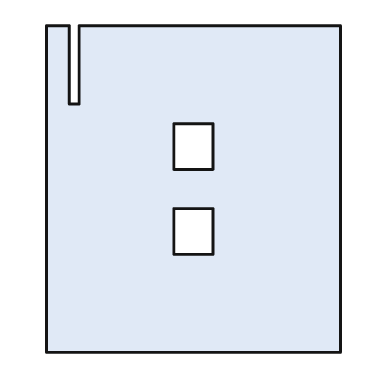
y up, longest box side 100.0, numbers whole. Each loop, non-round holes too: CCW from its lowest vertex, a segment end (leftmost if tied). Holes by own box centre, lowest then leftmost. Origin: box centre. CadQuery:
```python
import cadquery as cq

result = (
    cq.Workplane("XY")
    .moveTo(-45.0, -50.0)
    .lineTo(45.0, -50.0)
    .lineTo(45.0, 50.0)
    .lineTo(-35.0, 50.0)
    .lineTo(-35.0, 26.0)
    .lineTo(-38.0, 26.0)
    .lineTo(-38.0, 50.0)
    .lineTo(-45.0, 50.0)
    .close()
    .moveTo(-6.0, -20.0)
    .lineTo(6.0, -20.0)
    .lineTo(6.0, -6.0)
    .lineTo(-6.0, -6.0)
    .close()
    .moveTo(-6.0, 6.0)
    .lineTo(6.0, 6.0)
    .lineTo(6.0, 20.0)
    .lineTo(-6.0, 20.0)
    .close()
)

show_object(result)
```